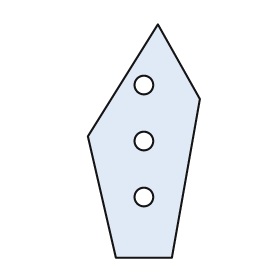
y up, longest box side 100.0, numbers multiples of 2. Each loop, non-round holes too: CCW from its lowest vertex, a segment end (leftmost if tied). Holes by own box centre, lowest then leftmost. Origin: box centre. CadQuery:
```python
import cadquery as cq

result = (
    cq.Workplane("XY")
    .moveTo(-12.0, -50.0)
    .lineTo(12.0, -50.0)
    .lineTo(24.0, 18.0)
    .lineTo(6.0, 50.0)
    .lineTo(-24.0, 2.0)
    .close()
    .moveTo(0.0, -24.0)
    .circle(4.0)
    .moveTo(0.0, 0.0)
    .circle(4.0)
    .moveTo(0.0, 24.0)
    .circle(4.0)
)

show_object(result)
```